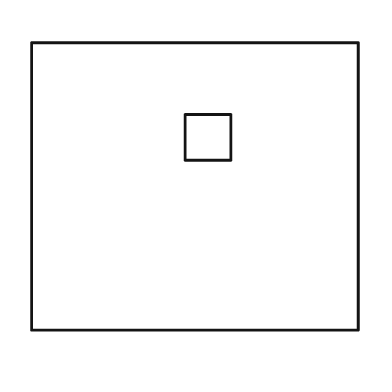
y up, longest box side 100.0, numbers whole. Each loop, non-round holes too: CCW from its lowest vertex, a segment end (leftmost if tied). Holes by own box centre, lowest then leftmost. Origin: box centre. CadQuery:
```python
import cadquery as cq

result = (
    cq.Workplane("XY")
    .moveTo(-50.0, -44.0)
    .lineTo(50.0, -44.0)
    .lineTo(50.0, 44.0)
    .lineTo(-50.0, 44.0)
    .close()
    .moveTo(-3.0, 8.0)
    .lineTo(11.0, 8.0)
    .lineTo(11.0, 22.0)
    .lineTo(-3.0, 22.0)
    .close()
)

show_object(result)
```